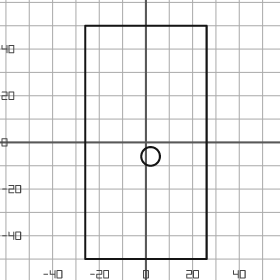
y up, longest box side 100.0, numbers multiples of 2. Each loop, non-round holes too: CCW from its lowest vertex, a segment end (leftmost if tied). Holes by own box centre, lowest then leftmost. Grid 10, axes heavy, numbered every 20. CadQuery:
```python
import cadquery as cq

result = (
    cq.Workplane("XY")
    .moveTo(-26.0, -50.0)
    .lineTo(26.0, -50.0)
    .lineTo(26.0, 50.0)
    .lineTo(-26.0, 50.0)
    .close()
    .moveTo(2.0, -6.0)
    .circle(4.0)
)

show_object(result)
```